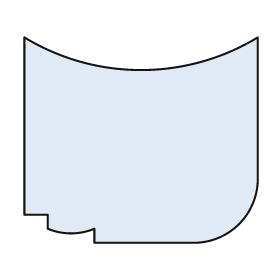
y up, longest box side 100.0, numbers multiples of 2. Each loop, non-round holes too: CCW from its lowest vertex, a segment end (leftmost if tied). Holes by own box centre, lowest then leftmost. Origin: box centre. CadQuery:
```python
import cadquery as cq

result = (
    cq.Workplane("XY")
    .moveTo(-20.0, -44.0)
    .lineTo(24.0, -44.0)
    .threePointArc((42.0, -36.0), (50.0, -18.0))
    .lineTo(50.0, 44.0)
    .threePointArc((0.0, 30.0), (-50.0, 44.0))
    .lineTo(-50.0, -32.0)
    .lineTo(-40.0, -32.0)
    .lineTo(-40.0, -38.0)
    .threePointArc((-30.0, -40.0), (-20.0, -38.0))
    .close()
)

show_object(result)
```